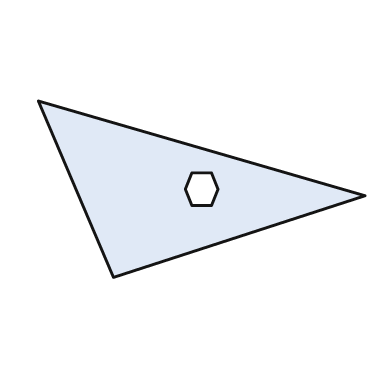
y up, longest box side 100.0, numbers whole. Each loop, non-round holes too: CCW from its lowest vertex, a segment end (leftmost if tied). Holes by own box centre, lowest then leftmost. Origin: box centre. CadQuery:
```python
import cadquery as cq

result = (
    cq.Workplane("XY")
    .moveTo(-27.0, -27.0)
    .lineTo(50.0, -2.0)
    .lineTo(-50.0, 27.0)
    .close()
    .moveTo(-3.0, -5.0)
    .lineTo(3.0, -5.0)
    .lineTo(5.0, 0.0)
    .lineTo(3.0, 5.0)
    .lineTo(-3.0, 5.0)
    .lineTo(-5.0, 0.0)
    .close()
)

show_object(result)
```